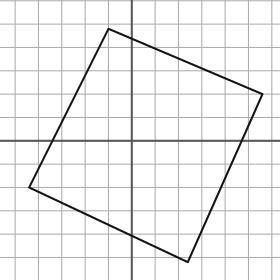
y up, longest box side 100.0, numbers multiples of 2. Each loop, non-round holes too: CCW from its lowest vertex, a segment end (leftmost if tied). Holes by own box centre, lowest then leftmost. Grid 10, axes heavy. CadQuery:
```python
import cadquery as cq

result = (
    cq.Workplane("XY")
    .moveTo(24.0, -52.0)
    .lineTo(56.0, 20.0)
    .lineTo(-10.0, 48.0)
    .lineTo(-44.0, -20.0)
    .close()
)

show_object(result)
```